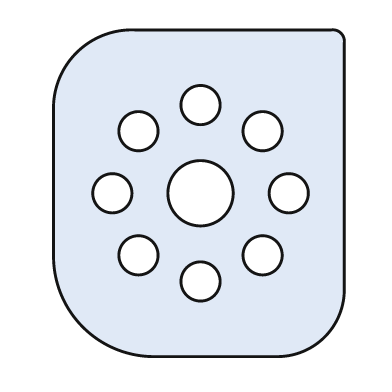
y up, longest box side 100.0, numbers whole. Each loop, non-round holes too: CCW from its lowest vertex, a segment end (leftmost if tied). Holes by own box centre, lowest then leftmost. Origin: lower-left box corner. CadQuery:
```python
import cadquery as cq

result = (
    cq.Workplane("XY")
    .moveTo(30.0, 0.0)
    .lineTo(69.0, 0.0)
    .threePointArc((83.0, 6.0), (89.0, 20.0))
    .lineTo(89.0, 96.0)
    .threePointArc((88.0, 99.0), (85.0, 100.0))
    .lineTo(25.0, 100.0)
    .threePointArc((7.0, 93.0), (0.0, 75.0))
    .lineTo(0.0, 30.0)
    .threePointArc((9.0, 9.0), (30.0, 0.0))
    .close()
    .moveTo(45.0, 23.0)
    .circle(6.0)
    .moveTo(26.0, 31.0)
    .circle(6.0)
    .moveTo(64.0, 31.0)
    .circle(6.0)
    .moveTo(18.0, 50.0)
    .circle(6.0)
    .moveTo(45.0, 50.0)
    .circle(10.0)
    .moveTo(72.0, 50.0)
    .circle(6.0)
    .moveTo(26.0, 69.0)
    .circle(6.0)
    .moveTo(64.0, 69.0)
    .circle(6.0)
    .moveTo(45.0, 77.0)
    .circle(6.0)
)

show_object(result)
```